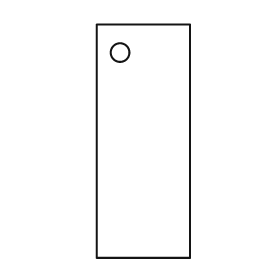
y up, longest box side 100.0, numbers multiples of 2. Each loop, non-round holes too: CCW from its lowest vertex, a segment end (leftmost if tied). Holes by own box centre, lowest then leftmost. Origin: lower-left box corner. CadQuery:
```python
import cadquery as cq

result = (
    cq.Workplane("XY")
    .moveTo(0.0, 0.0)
    .lineTo(40.0, 0.0)
    .lineTo(40.0, 100.0)
    .lineTo(0.0, 100.0)
    .close()
    .moveTo(10.0, 88.0)
    .circle(4.0)
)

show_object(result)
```